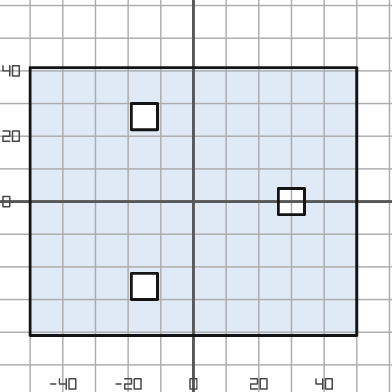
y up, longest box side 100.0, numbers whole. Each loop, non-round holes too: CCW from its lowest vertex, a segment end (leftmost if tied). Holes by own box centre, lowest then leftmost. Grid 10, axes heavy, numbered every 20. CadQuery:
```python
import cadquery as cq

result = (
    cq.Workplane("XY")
    .moveTo(-50.0, -41.0)
    .lineTo(50.0, -41.0)
    .lineTo(50.0, 41.0)
    .lineTo(-50.0, 41.0)
    .close()
    .moveTo(-19.0, -30.0)
    .lineTo(-11.0, -30.0)
    .lineTo(-11.0, -22.0)
    .lineTo(-19.0, -22.0)
    .close()
    .moveTo(26.0, -4.0)
    .lineTo(34.0, -4.0)
    .lineTo(34.0, 4.0)
    .lineTo(26.0, 4.0)
    .close()
    .moveTo(-19.0, 22.0)
    .lineTo(-11.0, 22.0)
    .lineTo(-11.0, 30.0)
    .lineTo(-19.0, 30.0)
    .close()
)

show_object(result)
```